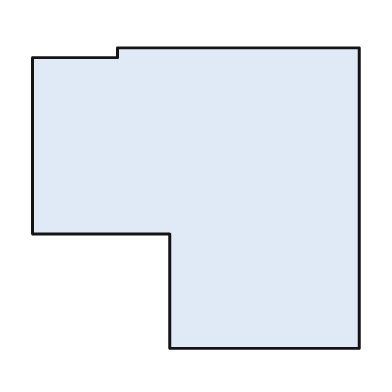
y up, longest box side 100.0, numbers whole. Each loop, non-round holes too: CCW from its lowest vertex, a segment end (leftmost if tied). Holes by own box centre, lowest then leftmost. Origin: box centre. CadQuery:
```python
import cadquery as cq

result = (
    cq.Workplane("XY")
    .moveTo(-8.0, -46.0)
    .lineTo(50.0, -46.0)
    .lineTo(50.0, 46.0)
    .lineTo(-24.0, 46.0)
    .lineTo(-24.0, 43.0)
    .lineTo(-50.0, 43.0)
    .lineTo(-50.0, -11.0)
    .lineTo(-8.0, -11.0)
    .close()
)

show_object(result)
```